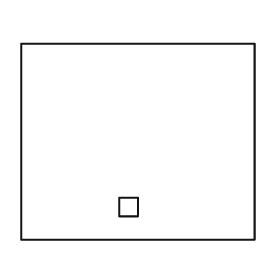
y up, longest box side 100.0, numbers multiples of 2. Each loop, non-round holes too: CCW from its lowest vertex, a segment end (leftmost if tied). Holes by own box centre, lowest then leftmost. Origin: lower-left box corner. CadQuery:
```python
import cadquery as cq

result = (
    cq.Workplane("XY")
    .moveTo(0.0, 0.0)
    .lineTo(100.0, 0.0)
    .lineTo(100.0, 84.0)
    .lineTo(0.0, 84.0)
    .close()
    .moveTo(42.0, 10.0)
    .lineTo(50.0, 10.0)
    .lineTo(50.0, 18.0)
    .lineTo(42.0, 18.0)
    .close()
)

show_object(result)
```